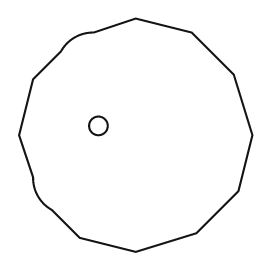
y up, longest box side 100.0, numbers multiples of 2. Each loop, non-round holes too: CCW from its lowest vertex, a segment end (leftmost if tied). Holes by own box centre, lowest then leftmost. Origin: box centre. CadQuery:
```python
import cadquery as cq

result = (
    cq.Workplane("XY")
    .moveTo(0.0, -50.0)
    .lineTo(26.0, -42.0)
    .lineTo(44.0, -24.0)
    .lineTo(50.0, 0.0)
    .lineTo(42.0, 26.0)
    .lineTo(24.0, 44.0)
    .lineTo(0.0, 50.0)
    .lineTo(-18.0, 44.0)
    .threePointArc((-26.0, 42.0), (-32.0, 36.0))
    .lineTo(-44.0, 24.0)
    .lineTo(-50.0, 0.0)
    .lineTo(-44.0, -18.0)
    .threePointArc((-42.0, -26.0), (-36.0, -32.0))
    .lineTo(-24.0, -44.0)
    .close()
    .moveTo(-16.0, 4.0)
    .circle(4.0)
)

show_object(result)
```